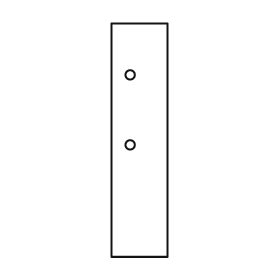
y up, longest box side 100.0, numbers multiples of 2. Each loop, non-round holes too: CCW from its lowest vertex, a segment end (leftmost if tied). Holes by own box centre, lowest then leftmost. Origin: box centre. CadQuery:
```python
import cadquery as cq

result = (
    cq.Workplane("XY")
    .moveTo(-12.0, -50.0)
    .lineTo(12.0, -50.0)
    .lineTo(12.0, 50.0)
    .lineTo(-12.0, 50.0)
    .close()
    .moveTo(-4.0, -2.0)
    .circle(2.0)
    .moveTo(-4.0, 28.0)
    .circle(2.0)
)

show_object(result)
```